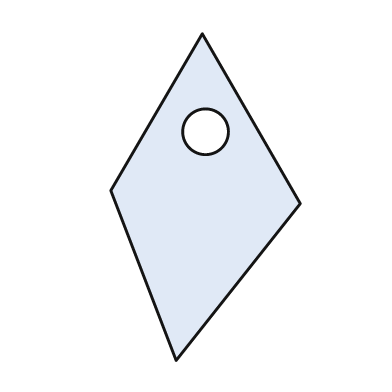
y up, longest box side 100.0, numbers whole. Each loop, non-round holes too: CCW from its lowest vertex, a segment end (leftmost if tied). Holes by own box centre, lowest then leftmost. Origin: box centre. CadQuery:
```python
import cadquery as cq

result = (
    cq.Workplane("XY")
    .moveTo(-9.0, -50.0)
    .lineTo(29.0, -2.0)
    .lineTo(-1.0, 50.0)
    .lineTo(-29.0, 2.0)
    .close()
    .moveTo(0.0, 20.0)
    .circle(7.0)
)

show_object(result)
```